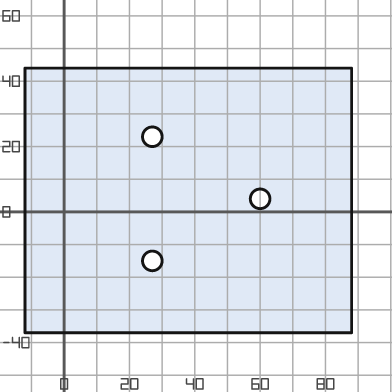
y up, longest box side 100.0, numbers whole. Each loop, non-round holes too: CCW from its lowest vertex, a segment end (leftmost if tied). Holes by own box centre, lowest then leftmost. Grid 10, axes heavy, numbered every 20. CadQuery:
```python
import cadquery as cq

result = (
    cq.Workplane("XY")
    .moveTo(-12.0, -37.0)
    .lineTo(88.0, -37.0)
    .lineTo(88.0, 44.0)
    .lineTo(-12.0, 44.0)
    .close()
    .moveTo(27.0, -15.0)
    .circle(3.0)
    .moveTo(60.0, 4.0)
    .circle(3.0)
    .moveTo(27.0, 23.0)
    .circle(3.0)
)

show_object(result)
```